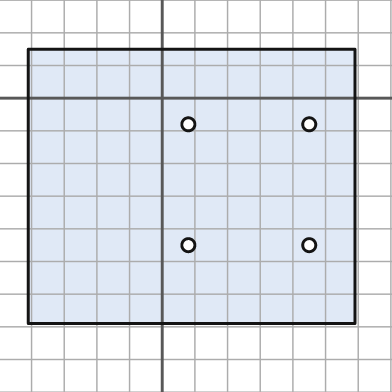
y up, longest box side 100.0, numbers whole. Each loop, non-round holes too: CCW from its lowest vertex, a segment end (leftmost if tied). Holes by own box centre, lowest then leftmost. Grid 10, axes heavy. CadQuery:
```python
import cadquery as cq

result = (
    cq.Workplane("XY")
    .moveTo(-41.0, -69.0)
    .lineTo(59.0, -69.0)
    .lineTo(59.0, 15.0)
    .lineTo(-41.0, 15.0)
    .close()
    .moveTo(8.0, -45.0)
    .circle(2.0)
    .moveTo(45.0, -45.0)
    .circle(2.0)
    .moveTo(8.0, -8.0)
    .circle(2.0)
    .moveTo(45.0, -8.0)
    .circle(2.0)
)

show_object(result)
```